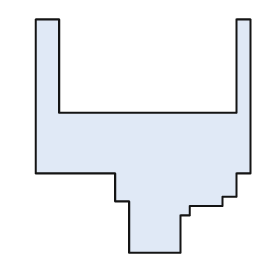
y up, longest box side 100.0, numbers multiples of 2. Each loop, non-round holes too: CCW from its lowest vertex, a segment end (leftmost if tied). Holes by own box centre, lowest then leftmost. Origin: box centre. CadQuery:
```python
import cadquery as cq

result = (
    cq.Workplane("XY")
    .moveTo(-6.0, -50.0)
    .lineTo(16.0, -50.0)
    .lineTo(16.0, -34.0)
    .lineTo(20.0, -34.0)
    .lineTo(20.0, -30.0)
    .lineTo(34.0, -30.0)
    .lineTo(34.0, -26.0)
    .lineTo(40.0, -26.0)
    .lineTo(40.0, -16.0)
    .lineTo(46.0, -16.0)
    .lineTo(46.0, 50.0)
    .lineTo(40.0, 50.0)
    .lineTo(40.0, 10.0)
    .lineTo(-36.0, 10.0)
    .lineTo(-36.0, 50.0)
    .lineTo(-46.0, 50.0)
    .lineTo(-46.0, -16.0)
    .lineTo(-12.0, -16.0)
    .lineTo(-12.0, -28.0)
    .lineTo(-6.0, -28.0)
    .close()
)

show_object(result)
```